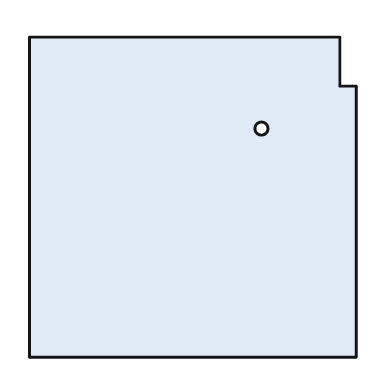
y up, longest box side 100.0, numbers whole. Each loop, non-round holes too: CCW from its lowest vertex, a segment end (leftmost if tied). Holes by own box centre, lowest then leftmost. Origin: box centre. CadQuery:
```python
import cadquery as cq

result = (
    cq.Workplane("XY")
    .moveTo(-50.0, -49.0)
    .lineTo(50.0, -49.0)
    .lineTo(50.0, 34.0)
    .lineTo(45.0, 34.0)
    .lineTo(45.0, 49.0)
    .lineTo(-50.0, 49.0)
    .close()
    .moveTo(21.0, 21.0)
    .circle(2.0)
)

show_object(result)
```